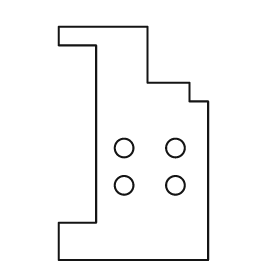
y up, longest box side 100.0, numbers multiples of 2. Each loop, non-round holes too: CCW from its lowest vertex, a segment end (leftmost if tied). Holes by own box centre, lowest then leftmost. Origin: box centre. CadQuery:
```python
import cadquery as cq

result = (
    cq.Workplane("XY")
    .moveTo(-32.0, -50.0)
    .lineTo(32.0, -50.0)
    .lineTo(32.0, 18.0)
    .lineTo(24.0, 18.0)
    .lineTo(24.0, 26.0)
    .lineTo(6.0, 26.0)
    .lineTo(6.0, 50.0)
    .lineTo(-32.0, 50.0)
    .lineTo(-32.0, 42.0)
    .lineTo(-16.0, 42.0)
    .lineTo(-16.0, -34.0)
    .lineTo(-32.0, -34.0)
    .close()
    .moveTo(-4.0, -18.0)
    .circle(4.0)
    .moveTo(18.0, -18.0)
    .circle(4.0)
    .moveTo(-4.0, -2.0)
    .circle(4.0)
    .moveTo(18.0, -2.0)
    .circle(4.0)
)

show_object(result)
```